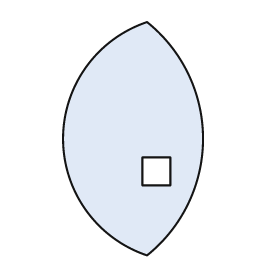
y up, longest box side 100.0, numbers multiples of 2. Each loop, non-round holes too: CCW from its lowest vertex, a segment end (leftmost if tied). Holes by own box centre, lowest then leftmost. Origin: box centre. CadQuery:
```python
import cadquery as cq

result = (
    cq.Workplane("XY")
    .moveTo(6.0, -50.0)
    .threePointArc((30.0, 0.0), (6.0, 50.0))
    .threePointArc((-30.0, 0.0), (6.0, -50.0))
    .close()
    .moveTo(4.0, -20.0)
    .lineTo(16.0, -20.0)
    .lineTo(16.0, -8.0)
    .lineTo(4.0, -8.0)
    .close()
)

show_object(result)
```